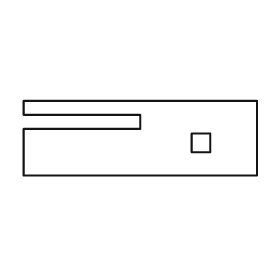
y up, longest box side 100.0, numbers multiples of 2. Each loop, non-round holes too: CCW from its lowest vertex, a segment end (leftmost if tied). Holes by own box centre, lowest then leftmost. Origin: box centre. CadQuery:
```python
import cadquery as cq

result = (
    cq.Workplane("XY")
    .moveTo(-50.0, -16.0)
    .lineTo(50.0, -16.0)
    .lineTo(50.0, 16.0)
    .lineTo(-50.0, 16.0)
    .lineTo(-50.0, 10.0)
    .lineTo(0.0, 10.0)
    .lineTo(0.0, 4.0)
    .lineTo(-50.0, 4.0)
    .close()
    .moveTo(22.0, -6.0)
    .lineTo(30.0, -6.0)
    .lineTo(30.0, 2.0)
    .lineTo(22.0, 2.0)
    .close()
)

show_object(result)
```